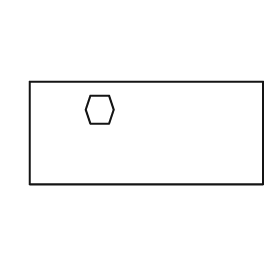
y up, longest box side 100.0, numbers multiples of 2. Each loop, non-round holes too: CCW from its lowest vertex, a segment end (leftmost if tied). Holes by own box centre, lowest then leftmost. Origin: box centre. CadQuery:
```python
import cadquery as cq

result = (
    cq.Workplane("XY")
    .moveTo(-50.0, -22.0)
    .lineTo(50.0, -22.0)
    .lineTo(50.0, 22.0)
    .lineTo(-50.0, 22.0)
    .close()
    .moveTo(-24.0, 4.0)
    .lineTo(-16.0, 4.0)
    .lineTo(-14.0, 10.0)
    .lineTo(-16.0, 16.0)
    .lineTo(-24.0, 16.0)
    .lineTo(-26.0, 10.0)
    .close()
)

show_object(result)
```